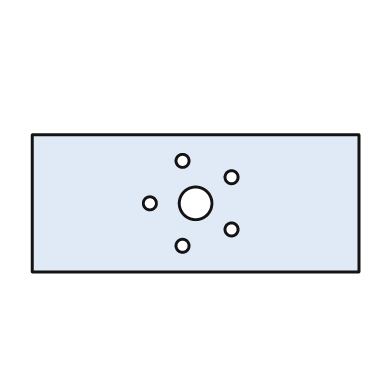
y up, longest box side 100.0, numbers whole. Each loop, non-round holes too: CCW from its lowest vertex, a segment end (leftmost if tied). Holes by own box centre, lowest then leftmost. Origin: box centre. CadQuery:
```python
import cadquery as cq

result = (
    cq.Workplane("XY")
    .moveTo(-50.0, -21.0)
    .lineTo(50.0, -21.0)
    .lineTo(50.0, 21.0)
    .lineTo(-50.0, 21.0)
    .close()
    .moveTo(-4.0, -13.0)
    .circle(2.0)
    .moveTo(11.0, -8.0)
    .circle(2.0)
    .moveTo(-14.0, 0.0)
    .circle(2.0)
    .moveTo(0.0, 0.0)
    .circle(5.0)
    .moveTo(11.0, 8.0)
    .circle(2.0)
    .moveTo(-4.0, 13.0)
    .circle(2.0)
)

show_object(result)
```